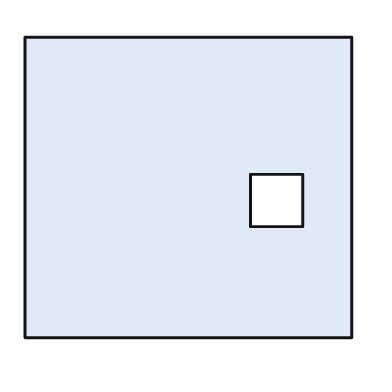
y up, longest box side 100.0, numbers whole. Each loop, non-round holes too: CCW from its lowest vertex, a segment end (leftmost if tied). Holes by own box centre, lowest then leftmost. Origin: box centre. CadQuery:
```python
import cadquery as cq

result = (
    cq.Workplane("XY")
    .moveTo(-50.0, -46.0)
    .lineTo(50.0, -46.0)
    .lineTo(50.0, 46.0)
    .lineTo(-50.0, 46.0)
    .close()
    .moveTo(19.0, -12.0)
    .lineTo(35.0, -12.0)
    .lineTo(35.0, 4.0)
    .lineTo(19.0, 4.0)
    .close()
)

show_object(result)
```